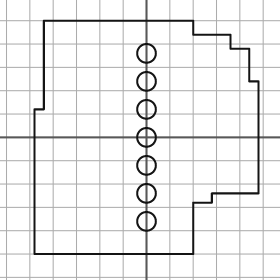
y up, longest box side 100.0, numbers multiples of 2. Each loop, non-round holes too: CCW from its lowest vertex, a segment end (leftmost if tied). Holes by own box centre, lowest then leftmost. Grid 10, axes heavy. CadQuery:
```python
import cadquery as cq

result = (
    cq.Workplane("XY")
    .moveTo(-48.0, -50.0)
    .lineTo(20.0, -50.0)
    .lineTo(20.0, -28.0)
    .lineTo(28.0, -28.0)
    .lineTo(28.0, -24.0)
    .lineTo(48.0, -24.0)
    .lineTo(48.0, 24.0)
    .lineTo(44.0, 24.0)
    .lineTo(44.0, 38.0)
    .lineTo(36.0, 38.0)
    .lineTo(36.0, 44.0)
    .lineTo(20.0, 44.0)
    .lineTo(20.0, 50.0)
    .lineTo(-44.0, 50.0)
    .lineTo(-44.0, 12.0)
    .lineTo(-48.0, 12.0)
    .close()
    .moveTo(0.0, -36.0)
    .circle(4.0)
    .moveTo(0.0, -24.0)
    .circle(4.0)
    .moveTo(0.0, -12.0)
    .circle(4.0)
    .moveTo(0.0, 0.0)
    .circle(4.0)
    .moveTo(0.0, 12.0)
    .circle(4.0)
    .moveTo(0.0, 24.0)
    .circle(4.0)
    .moveTo(0.0, 36.0)
    .circle(4.0)
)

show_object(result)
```